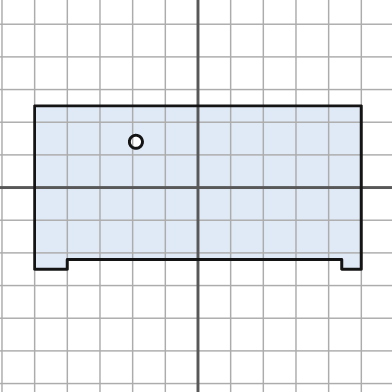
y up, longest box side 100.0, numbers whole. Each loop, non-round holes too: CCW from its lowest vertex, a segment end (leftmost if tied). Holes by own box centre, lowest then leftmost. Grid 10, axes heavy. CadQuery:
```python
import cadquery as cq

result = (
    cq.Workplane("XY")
    .moveTo(-50.0, -25.0)
    .lineTo(-40.0, -25.0)
    .lineTo(-40.0, -22.0)
    .lineTo(44.0, -22.0)
    .lineTo(44.0, -25.0)
    .lineTo(50.0, -25.0)
    .lineTo(50.0, 25.0)
    .lineTo(-50.0, 25.0)
    .close()
    .moveTo(-19.0, 14.0)
    .circle(2.0)
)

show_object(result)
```